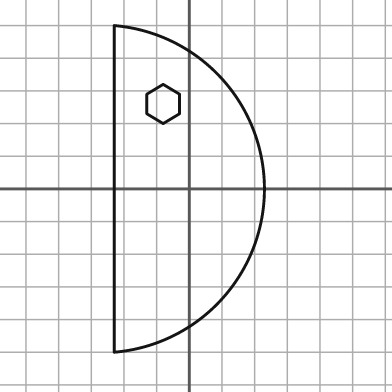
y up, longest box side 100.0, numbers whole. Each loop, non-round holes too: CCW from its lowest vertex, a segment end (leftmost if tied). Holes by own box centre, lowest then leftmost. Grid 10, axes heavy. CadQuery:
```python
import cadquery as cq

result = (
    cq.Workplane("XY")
    .moveTo(-23.0, -50.0)
    .threePointArc((23.0, 0.0), (-23.0, 50.0))
    .close()
    .moveTo(-8.0, 20.0)
    .lineTo(-3.0, 23.0)
    .lineTo(-3.0, 29.0)
    .lineTo(-8.0, 32.0)
    .lineTo(-13.0, 29.0)
    .lineTo(-13.0, 23.0)
    .close()
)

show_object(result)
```